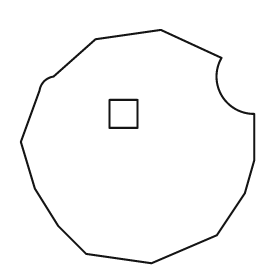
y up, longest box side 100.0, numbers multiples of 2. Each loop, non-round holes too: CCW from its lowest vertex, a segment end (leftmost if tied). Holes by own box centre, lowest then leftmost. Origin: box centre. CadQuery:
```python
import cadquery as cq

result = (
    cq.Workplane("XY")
    .moveTo(6.0, -50.0)
    .lineTo(34.0, -38.0)
    .lineTo(46.0, -20.0)
    .lineTo(50.0, -6.0)
    .lineTo(50.0, 14.0)
    .threePointArc((36.0, 22.0), (36.0, 38.0))
    .lineTo(10.0, 50.0)
    .lineTo(-18.0, 46.0)
    .lineTo(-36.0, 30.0)
    .threePointArc((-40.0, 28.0), (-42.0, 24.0))
    .lineTo(-50.0, 2.0)
    .lineTo(-44.0, -18.0)
    .lineTo(-34.0, -34.0)
    .lineTo(-22.0, -46.0)
    .close()
    .moveTo(-12.0, 8.0)
    .lineTo(0.0, 8.0)
    .lineTo(0.0, 20.0)
    .lineTo(-12.0, 20.0)
    .close()
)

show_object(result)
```